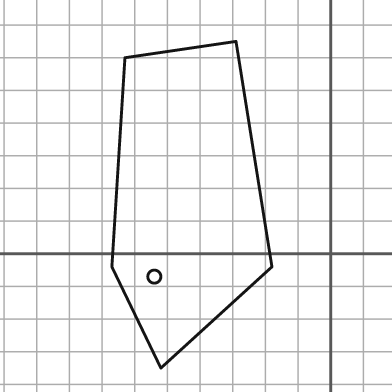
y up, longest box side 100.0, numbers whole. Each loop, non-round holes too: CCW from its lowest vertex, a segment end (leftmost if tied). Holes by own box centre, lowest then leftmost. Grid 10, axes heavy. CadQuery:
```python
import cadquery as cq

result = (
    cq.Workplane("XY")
    .moveTo(-52.0, -35.0)
    .lineTo(-18.0, -4.0)
    .lineTo(-29.0, 65.0)
    .lineTo(-63.0, 60.0)
    .lineTo(-67.0, -4.0)
    .close()
    .moveTo(-54.0, -7.0)
    .circle(2.0)
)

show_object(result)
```